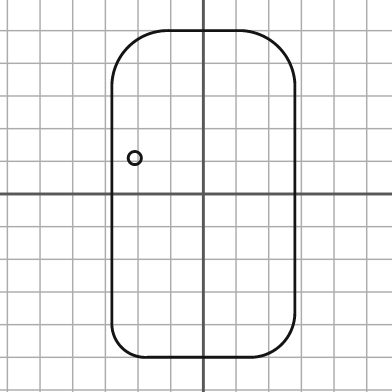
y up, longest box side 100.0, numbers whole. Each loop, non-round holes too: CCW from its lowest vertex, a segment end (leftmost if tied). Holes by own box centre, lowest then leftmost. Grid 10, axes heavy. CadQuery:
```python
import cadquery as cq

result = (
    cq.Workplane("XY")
    .moveTo(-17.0, -50.0)
    .lineTo(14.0, -50.0)
    .threePointArc((24.0, -46.0), (28.0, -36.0))
    .lineTo(28.0, 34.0)
    .threePointArc((23.0, 45.0), (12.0, 50.0))
    .lineTo(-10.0, 50.0)
    .threePointArc((-23.0, 45.0), (-28.0, 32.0))
    .lineTo(-28.0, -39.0)
    .threePointArc((-25.0, -47.0), (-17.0, -50.0))
    .close()
    .moveTo(-21.0, 11.0)
    .circle(2.0)
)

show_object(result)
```